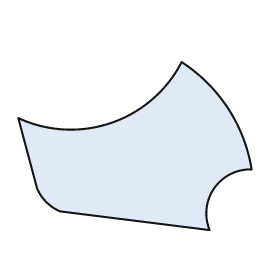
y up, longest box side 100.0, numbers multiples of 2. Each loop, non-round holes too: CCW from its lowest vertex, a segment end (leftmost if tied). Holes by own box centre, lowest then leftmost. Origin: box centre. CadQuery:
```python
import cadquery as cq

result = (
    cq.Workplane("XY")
    .moveTo(32.0, -36.0)
    .threePointArc((34.0, -18.0), (50.0, -10.0))
    .threePointArc((40.0, 16.0), (20.0, 36.0))
    .threePointArc((-10.0, 10.0), (-50.0, 12.0))
    .lineTo(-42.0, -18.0)
    .threePointArc((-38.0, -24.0), (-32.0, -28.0))
    .close()
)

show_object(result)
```